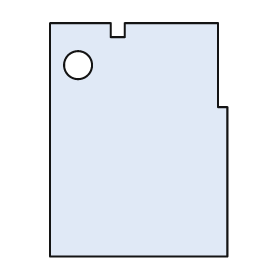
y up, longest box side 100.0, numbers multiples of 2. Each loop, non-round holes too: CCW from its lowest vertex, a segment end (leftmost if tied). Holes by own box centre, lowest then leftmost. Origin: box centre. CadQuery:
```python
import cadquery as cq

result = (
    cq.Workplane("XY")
    .moveTo(-38.0, -50.0)
    .lineTo(38.0, -50.0)
    .lineTo(38.0, 14.0)
    .lineTo(34.0, 14.0)
    .lineTo(34.0, 50.0)
    .lineTo(-6.0, 50.0)
    .lineTo(-6.0, 44.0)
    .lineTo(-12.0, 44.0)
    .lineTo(-12.0, 50.0)
    .lineTo(-38.0, 50.0)
    .close()
    .moveTo(-26.0, 32.0)
    .circle(6.0)
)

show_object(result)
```